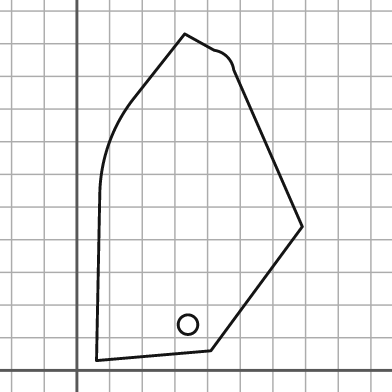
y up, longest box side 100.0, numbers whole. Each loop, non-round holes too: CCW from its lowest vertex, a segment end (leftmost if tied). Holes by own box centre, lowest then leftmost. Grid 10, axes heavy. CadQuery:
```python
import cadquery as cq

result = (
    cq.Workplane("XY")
    .moveTo(6.0, 3.0)
    .lineTo(41.0, 6.0)
    .lineTo(69.0, 44.0)
    .lineTo(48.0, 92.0)
    .threePointArc((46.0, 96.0), (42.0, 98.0))
    .lineTo(33.0, 103.0)
    .lineTo(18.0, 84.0)
    .threePointArc((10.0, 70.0), (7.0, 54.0))
    .close()
    .moveTo(34.0, 14.0)
    .circle(3.0)
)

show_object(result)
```